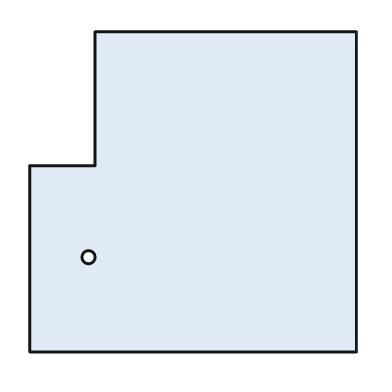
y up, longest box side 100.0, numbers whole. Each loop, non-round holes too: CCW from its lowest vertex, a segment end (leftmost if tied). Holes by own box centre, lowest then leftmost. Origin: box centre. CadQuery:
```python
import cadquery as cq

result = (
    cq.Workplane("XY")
    .moveTo(-50.0, -49.0)
    .lineTo(50.0, -49.0)
    .lineTo(50.0, 49.0)
    .lineTo(-30.0, 49.0)
    .lineTo(-30.0, 8.0)
    .lineTo(-50.0, 8.0)
    .close()
    .moveTo(-32.0, -20.0)
    .circle(2.0)
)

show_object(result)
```